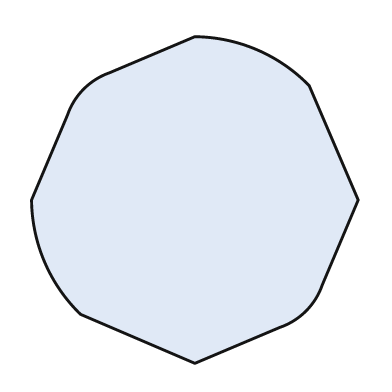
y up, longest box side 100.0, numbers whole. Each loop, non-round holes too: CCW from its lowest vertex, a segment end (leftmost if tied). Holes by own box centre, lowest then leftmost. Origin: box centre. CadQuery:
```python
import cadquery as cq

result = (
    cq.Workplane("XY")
    .moveTo(0.0, -50.0)
    .lineTo(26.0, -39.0)
    .threePointArc((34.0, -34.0), (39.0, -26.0))
    .lineTo(50.0, 0.0)
    .lineTo(35.0, 35.0)
    .threePointArc((19.0, 46.0), (0.0, 50.0))
    .lineTo(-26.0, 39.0)
    .threePointArc((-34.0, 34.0), (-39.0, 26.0))
    .lineTo(-50.0, 0.0)
    .threePointArc((-46.0, -19.0), (-35.0, -35.0))
    .close()
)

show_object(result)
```